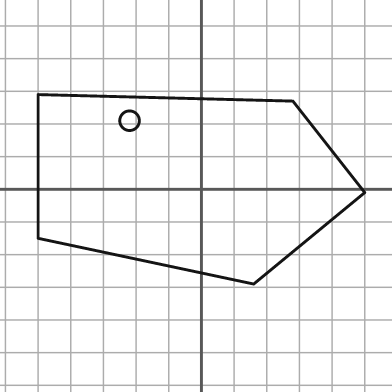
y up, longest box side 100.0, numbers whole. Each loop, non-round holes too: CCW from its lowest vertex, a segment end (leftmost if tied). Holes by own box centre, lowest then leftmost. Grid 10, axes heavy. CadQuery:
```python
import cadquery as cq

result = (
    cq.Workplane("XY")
    .moveTo(16.0, -29.0)
    .lineTo(50.0, -1.0)
    .lineTo(28.0, 27.0)
    .lineTo(-50.0, 29.0)
    .lineTo(-50.0, -15.0)
    .close()
    .moveTo(-22.0, 21.0)
    .circle(3.0)
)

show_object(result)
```